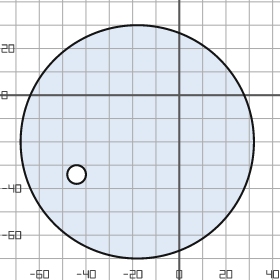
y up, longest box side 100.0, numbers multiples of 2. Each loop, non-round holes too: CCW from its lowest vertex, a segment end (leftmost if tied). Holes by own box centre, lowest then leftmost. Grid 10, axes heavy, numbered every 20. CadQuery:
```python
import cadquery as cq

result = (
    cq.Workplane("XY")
    .moveTo(-18.0, -20.0)
    .circle(50.0)
    .moveTo(-44.0, -34.0)
    .circle(4.0)
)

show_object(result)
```